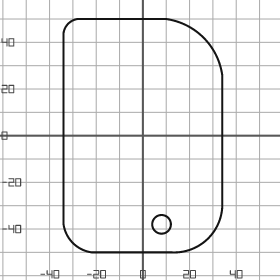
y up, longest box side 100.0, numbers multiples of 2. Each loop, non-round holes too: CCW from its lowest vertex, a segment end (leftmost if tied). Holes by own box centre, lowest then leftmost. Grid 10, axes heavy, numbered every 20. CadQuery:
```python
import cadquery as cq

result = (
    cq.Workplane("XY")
    .moveTo(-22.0, -50.0)
    .lineTo(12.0, -50.0)
    .threePointArc((28.0, -44.0), (34.0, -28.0))
    .lineTo(34.0, 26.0)
    .threePointArc((26.0, 42.0), (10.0, 50.0))
    .lineTo(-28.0, 50.0)
    .threePointArc((-32.0, 48.0), (-34.0, 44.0))
    .lineTo(-34.0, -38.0)
    .threePointArc((-30.0, -46.0), (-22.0, -50.0))
    .close()
    .moveTo(8.0, -38.0)
    .circle(4.0)
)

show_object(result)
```